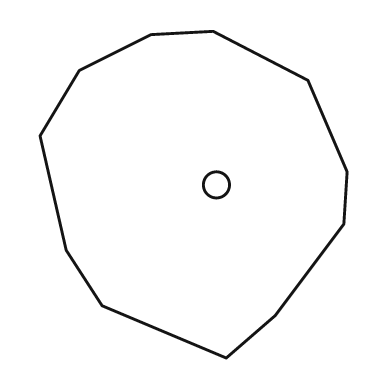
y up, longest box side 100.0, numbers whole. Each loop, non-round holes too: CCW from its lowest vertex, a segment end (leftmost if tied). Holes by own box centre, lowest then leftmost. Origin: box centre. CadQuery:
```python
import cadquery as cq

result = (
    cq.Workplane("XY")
    .moveTo(10.0, -50.0)
    .lineTo(25.0, -37.0)
    .lineTo(46.0, -9.0)
    .lineTo(47.0, 7.0)
    .lineTo(35.0, 35.0)
    .lineTo(6.0, 50.0)
    .lineTo(-13.0, 49.0)
    .lineTo(-35.0, 38.0)
    .lineTo(-47.0, 18.0)
    .lineTo(-39.0, -17.0)
    .lineTo(-28.0, -34.0)
    .close()
    .moveTo(7.0, 3.0)
    .circle(4.0)
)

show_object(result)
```